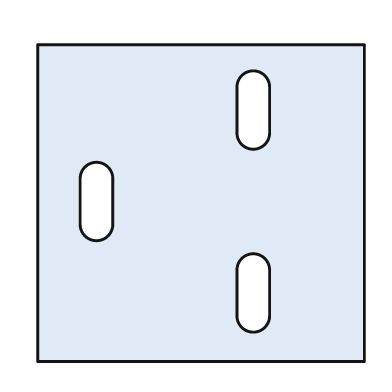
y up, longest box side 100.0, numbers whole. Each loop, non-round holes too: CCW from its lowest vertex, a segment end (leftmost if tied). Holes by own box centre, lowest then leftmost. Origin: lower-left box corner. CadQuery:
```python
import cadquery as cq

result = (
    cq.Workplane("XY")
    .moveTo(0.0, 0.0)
    .lineTo(100.0, 0.0)
    .lineTo(100.0, 97.0)
    .lineTo(0.0, 97.0)
    .close()
    .moveTo(61.0, 14.0)
    .threePointArc((66.0, 9.0), (71.0, 14.0))
    .lineTo(71.0, 28.0)
    .threePointArc((66.0, 33.0), (61.0, 28.0))
    .close()
    .moveTo(13.0, 42.0)
    .threePointArc((18.0, 37.0), (23.0, 42.0))
    .lineTo(23.0, 56.0)
    .threePointArc((18.0, 61.0), (13.0, 56.0))
    .close()
    .moveTo(61.0, 70.0)
    .threePointArc((66.0, 65.0), (71.0, 70.0))
    .lineTo(71.0, 84.0)
    .threePointArc((66.0, 89.0), (61.0, 84.0))
    .close()
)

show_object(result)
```